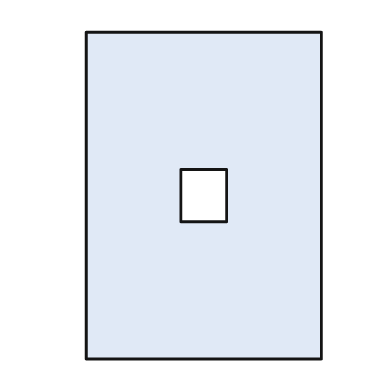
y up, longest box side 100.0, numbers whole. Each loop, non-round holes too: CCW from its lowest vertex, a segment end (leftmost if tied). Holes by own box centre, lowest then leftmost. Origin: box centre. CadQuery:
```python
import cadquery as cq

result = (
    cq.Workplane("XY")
    .moveTo(-36.0, -50.0)
    .lineTo(36.0, -50.0)
    .lineTo(36.0, 50.0)
    .lineTo(-36.0, 50.0)
    .close()
    .moveTo(-7.0, -8.0)
    .lineTo(7.0, -8.0)
    .lineTo(7.0, 8.0)
    .lineTo(-7.0, 8.0)
    .close()
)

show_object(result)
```